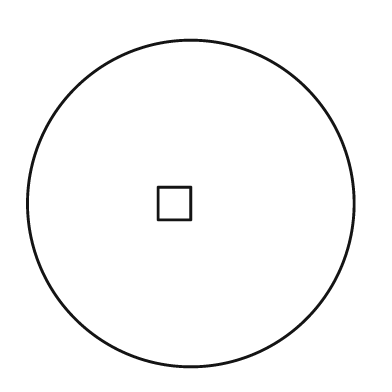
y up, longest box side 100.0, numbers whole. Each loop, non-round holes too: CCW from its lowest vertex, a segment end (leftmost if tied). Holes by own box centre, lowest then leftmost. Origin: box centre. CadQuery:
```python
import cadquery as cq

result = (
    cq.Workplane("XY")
    .moveTo(0.0, 0.0)
    .circle(50.0)
    .moveTo(-10.0, -5.0)
    .lineTo(0.0, -5.0)
    .lineTo(0.0, 5.0)
    .lineTo(-10.0, 5.0)
    .close()
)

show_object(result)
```